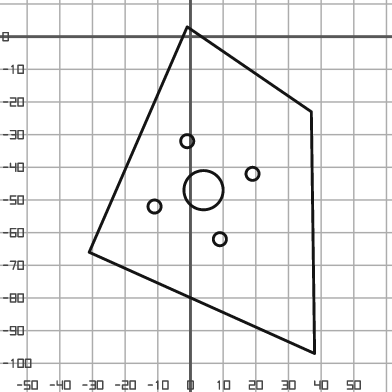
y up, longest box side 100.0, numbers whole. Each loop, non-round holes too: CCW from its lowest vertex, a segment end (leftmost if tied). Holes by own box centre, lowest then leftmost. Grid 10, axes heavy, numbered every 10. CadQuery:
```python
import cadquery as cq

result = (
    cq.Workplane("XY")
    .moveTo(38.0, -97.0)
    .lineTo(37.0, -23.0)
    .lineTo(-1.0, 3.0)
    .lineTo(-31.0, -66.0)
    .close()
    .moveTo(9.0, -62.0)
    .circle(2.0)
    .moveTo(-11.0, -52.0)
    .circle(2.0)
    .moveTo(4.0, -47.0)
    .circle(6.0)
    .moveTo(19.0, -42.0)
    .circle(2.0)
    .moveTo(-1.0, -32.0)
    .circle(2.0)
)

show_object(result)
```